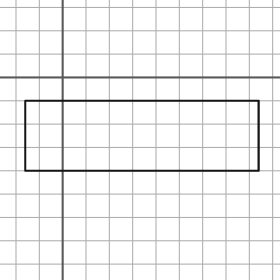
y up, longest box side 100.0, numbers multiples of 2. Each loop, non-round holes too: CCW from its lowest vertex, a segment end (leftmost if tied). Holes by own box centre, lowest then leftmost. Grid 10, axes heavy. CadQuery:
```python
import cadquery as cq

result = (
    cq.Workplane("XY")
    .moveTo(-16.0, -40.0)
    .lineTo(84.0, -40.0)
    .lineTo(84.0, -10.0)
    .lineTo(-16.0, -10.0)
    .close()
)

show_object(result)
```